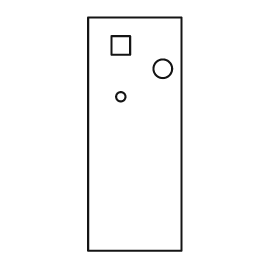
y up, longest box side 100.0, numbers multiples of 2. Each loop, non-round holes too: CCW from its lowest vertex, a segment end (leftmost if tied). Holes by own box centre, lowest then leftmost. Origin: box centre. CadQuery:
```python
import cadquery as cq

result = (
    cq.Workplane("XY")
    .moveTo(-20.0, -50.0)
    .lineTo(20.0, -50.0)
    .lineTo(20.0, 50.0)
    .lineTo(-20.0, 50.0)
    .close()
    .moveTo(-6.0, 16.0)
    .circle(2.0)
    .moveTo(12.0, 28.0)
    .circle(4.0)
    .moveTo(-10.0, 34.0)
    .lineTo(-2.0, 34.0)
    .lineTo(-2.0, 42.0)
    .lineTo(-10.0, 42.0)
    .close()
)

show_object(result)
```